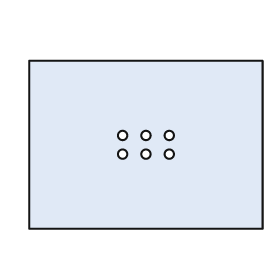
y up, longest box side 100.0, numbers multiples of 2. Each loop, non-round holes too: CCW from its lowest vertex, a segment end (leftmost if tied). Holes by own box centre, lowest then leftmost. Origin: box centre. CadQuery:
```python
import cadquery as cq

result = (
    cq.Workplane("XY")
    .moveTo(-50.0, -36.0)
    .lineTo(50.0, -36.0)
    .lineTo(50.0, 36.0)
    .lineTo(-50.0, 36.0)
    .close()
    .moveTo(-10.0, -4.0)
    .circle(2.0)
    .moveTo(0.0, -4.0)
    .circle(2.0)
    .moveTo(10.0, -4.0)
    .circle(2.0)
    .moveTo(-10.0, 4.0)
    .circle(2.0)
    .moveTo(0.0, 4.0)
    .circle(2.0)
    .moveTo(10.0, 4.0)
    .circle(2.0)
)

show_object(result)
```